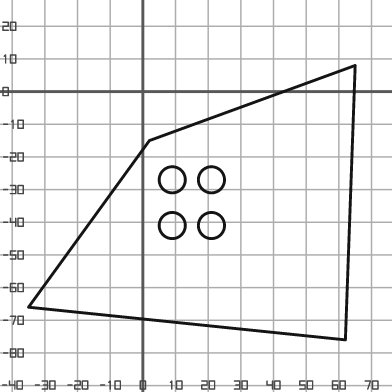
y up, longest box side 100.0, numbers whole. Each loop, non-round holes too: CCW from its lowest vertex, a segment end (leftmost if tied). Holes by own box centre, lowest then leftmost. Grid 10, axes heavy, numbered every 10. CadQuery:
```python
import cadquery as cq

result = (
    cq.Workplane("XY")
    .moveTo(62.0, -76.0)
    .lineTo(65.0, 8.0)
    .lineTo(2.0, -15.0)
    .lineTo(-35.0, -66.0)
    .close()
    .moveTo(9.0, -41.0)
    .circle(4.0)
    .moveTo(21.0, -41.0)
    .circle(4.0)
    .moveTo(9.0, -27.0)
    .circle(4.0)
    .moveTo(21.0, -27.0)
    .circle(4.0)
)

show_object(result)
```